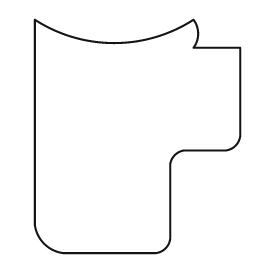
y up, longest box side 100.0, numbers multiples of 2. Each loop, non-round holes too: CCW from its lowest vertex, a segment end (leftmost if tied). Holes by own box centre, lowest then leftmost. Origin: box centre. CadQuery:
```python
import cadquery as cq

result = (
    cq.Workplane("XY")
    .moveTo(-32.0, -50.0)
    .lineTo(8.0, -50.0)
    .threePointArc((12.0, -48.0), (14.0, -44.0))
    .lineTo(14.0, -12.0)
    .threePointArc((16.0, -8.0), (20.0, -6.0))
    .lineTo(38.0, -6.0)
    .threePointArc((42.0, -4.0), (44.0, 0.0))
    .lineTo(44.0, 38.0)
    .lineTo(24.0, 38.0)
    .threePointArc((26.0, 44.0), (24.0, 50.0))
    .threePointArc((-10.0, 40.0), (-44.0, 50.0))
    .lineTo(-44.0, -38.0)
    .threePointArc((-40.0, -46.0), (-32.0, -50.0))
    .close()
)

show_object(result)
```